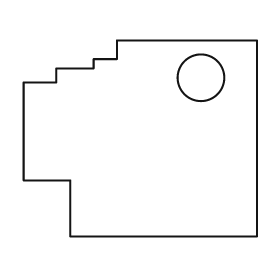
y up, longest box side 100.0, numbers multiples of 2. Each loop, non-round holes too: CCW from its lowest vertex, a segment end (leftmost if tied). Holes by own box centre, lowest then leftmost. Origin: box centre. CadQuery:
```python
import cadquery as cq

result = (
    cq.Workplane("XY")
    .moveTo(-30.0, -42.0)
    .lineTo(50.0, -42.0)
    .lineTo(50.0, 42.0)
    .lineTo(-10.0, 42.0)
    .lineTo(-10.0, 34.0)
    .lineTo(-20.0, 34.0)
    .lineTo(-20.0, 30.0)
    .lineTo(-36.0, 30.0)
    .lineTo(-36.0, 24.0)
    .lineTo(-50.0, 24.0)
    .lineTo(-50.0, -18.0)
    .lineTo(-30.0, -18.0)
    .close()
    .moveTo(26.0, 26.0)
    .circle(10.0)
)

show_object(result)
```